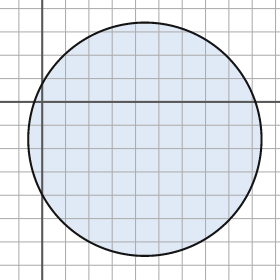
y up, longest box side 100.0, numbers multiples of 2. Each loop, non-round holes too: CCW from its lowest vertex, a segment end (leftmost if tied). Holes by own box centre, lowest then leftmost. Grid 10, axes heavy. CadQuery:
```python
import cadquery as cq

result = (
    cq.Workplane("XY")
    .moveTo(44.0, -16.0)
    .circle(50.0)
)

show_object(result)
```